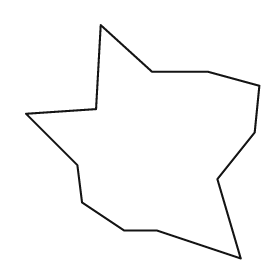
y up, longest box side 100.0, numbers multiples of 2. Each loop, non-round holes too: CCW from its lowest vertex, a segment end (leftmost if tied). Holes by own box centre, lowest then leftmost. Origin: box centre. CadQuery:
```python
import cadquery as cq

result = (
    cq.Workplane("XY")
    .moveTo(42.0, -50.0)
    .lineTo(32.0, -16.0)
    .lineTo(48.0, 4.0)
    .lineTo(50.0, 24.0)
    .lineTo(28.0, 30.0)
    .lineTo(4.0, 30.0)
    .lineTo(-18.0, 50.0)
    .lineTo(-20.0, 14.0)
    .lineTo(-50.0, 12.0)
    .lineTo(-28.0, -10.0)
    .lineTo(-26.0, -26.0)
    .lineTo(-8.0, -38.0)
    .lineTo(6.0, -38.0)
    .close()
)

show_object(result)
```